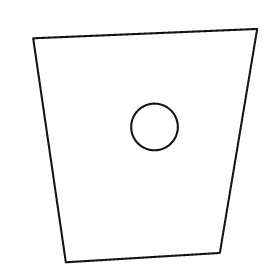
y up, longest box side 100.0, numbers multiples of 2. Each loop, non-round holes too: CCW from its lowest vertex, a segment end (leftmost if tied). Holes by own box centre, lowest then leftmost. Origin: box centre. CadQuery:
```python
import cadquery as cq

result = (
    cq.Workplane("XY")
    .moveTo(-34.0, -50.0)
    .lineTo(32.0, -46.0)
    .lineTo(48.0, 50.0)
    .lineTo(-48.0, 46.0)
    .close()
    .moveTo(4.0, 8.0)
    .circle(10.0)
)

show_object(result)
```